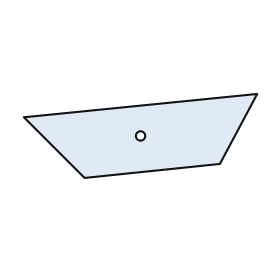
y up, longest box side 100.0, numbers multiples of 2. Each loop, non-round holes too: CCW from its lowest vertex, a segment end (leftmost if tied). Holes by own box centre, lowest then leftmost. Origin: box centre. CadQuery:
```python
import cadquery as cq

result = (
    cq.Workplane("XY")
    .moveTo(-24.0, -18.0)
    .lineTo(34.0, -12.0)
    .lineTo(50.0, 18.0)
    .lineTo(-50.0, 8.0)
    .close()
    .moveTo(0.0, 0.0)
    .circle(2.0)
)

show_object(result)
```